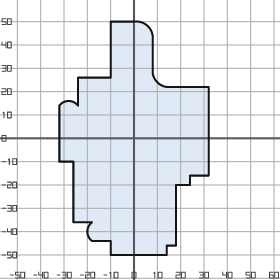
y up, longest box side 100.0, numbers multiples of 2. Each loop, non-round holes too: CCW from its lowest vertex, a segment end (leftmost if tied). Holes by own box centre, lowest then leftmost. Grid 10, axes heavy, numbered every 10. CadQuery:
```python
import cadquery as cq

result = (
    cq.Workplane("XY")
    .moveTo(-10.0, -50.0)
    .lineTo(14.0, -50.0)
    .lineTo(14.0, -46.0)
    .lineTo(18.0, -46.0)
    .lineTo(18.0, -20.0)
    .lineTo(24.0, -20.0)
    .lineTo(24.0, -16.0)
    .lineTo(32.0, -16.0)
    .lineTo(32.0, 22.0)
    .lineTo(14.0, 22.0)
    .threePointArc((10.0, 24.0), (8.0, 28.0))
    .lineTo(8.0, 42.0)
    .threePointArc((6.0, 48.0), (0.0, 50.0))
    .lineTo(-10.0, 50.0)
    .lineTo(-10.0, 26.0)
    .lineTo(-24.0, 26.0)
    .lineTo(-24.0, 14.0)
    .threePointArc((-28.0, 16.0), (-32.0, 14.0))
    .lineTo(-32.0, -10.0)
    .lineTo(-26.0, -10.0)
    .lineTo(-26.0, -36.0)
    .lineTo(-18.0, -36.0)
    .threePointArc((-20.0, -40.0), (-18.0, -44.0))
    .lineTo(-10.0, -44.0)
    .close()
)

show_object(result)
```